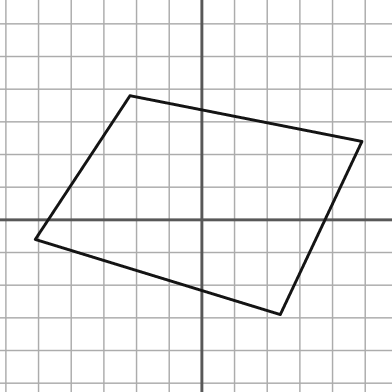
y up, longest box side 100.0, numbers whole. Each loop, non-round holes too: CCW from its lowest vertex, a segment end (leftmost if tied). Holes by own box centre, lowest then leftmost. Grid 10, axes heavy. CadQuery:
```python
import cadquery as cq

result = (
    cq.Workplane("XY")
    .moveTo(24.0, -29.0)
    .lineTo(49.0, 24.0)
    .lineTo(-22.0, 38.0)
    .lineTo(-51.0, -6.0)
    .close()
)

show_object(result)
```